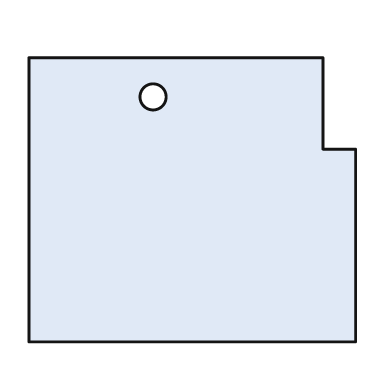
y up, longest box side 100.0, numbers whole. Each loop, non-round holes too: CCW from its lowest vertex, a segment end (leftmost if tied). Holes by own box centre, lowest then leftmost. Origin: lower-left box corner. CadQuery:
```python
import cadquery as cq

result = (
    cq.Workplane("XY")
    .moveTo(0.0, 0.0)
    .lineTo(100.0, 0.0)
    .lineTo(100.0, 59.0)
    .lineTo(90.0, 59.0)
    .lineTo(90.0, 87.0)
    .lineTo(0.0, 87.0)
    .close()
    .moveTo(38.0, 75.0)
    .circle(4.0)
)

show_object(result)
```